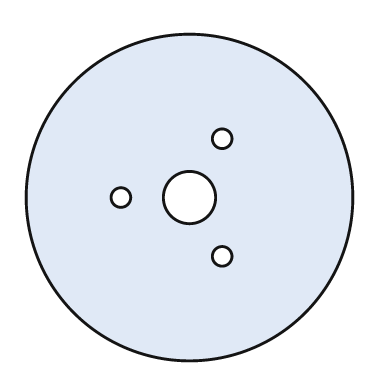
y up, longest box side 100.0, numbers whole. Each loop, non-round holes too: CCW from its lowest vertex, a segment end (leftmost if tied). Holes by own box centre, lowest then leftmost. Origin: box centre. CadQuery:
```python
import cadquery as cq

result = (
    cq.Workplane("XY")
    .moveTo(0.0, 0.0)
    .circle(50.0)
    .moveTo(10.0, -18.0)
    .circle(3.0)
    .moveTo(-21.0, 0.0)
    .circle(3.0)
    .moveTo(0.0, 0.0)
    .circle(8.0)
    .moveTo(10.0, 18.0)
    .circle(3.0)
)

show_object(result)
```